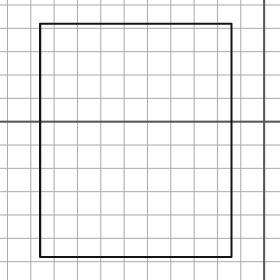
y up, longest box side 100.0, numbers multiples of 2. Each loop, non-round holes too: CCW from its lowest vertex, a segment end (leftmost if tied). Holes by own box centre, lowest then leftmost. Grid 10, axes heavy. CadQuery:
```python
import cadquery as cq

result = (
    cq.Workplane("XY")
    .moveTo(-96.0, -58.0)
    .lineTo(-14.0, -58.0)
    .lineTo(-14.0, 42.0)
    .lineTo(-96.0, 42.0)
    .close()
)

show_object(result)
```